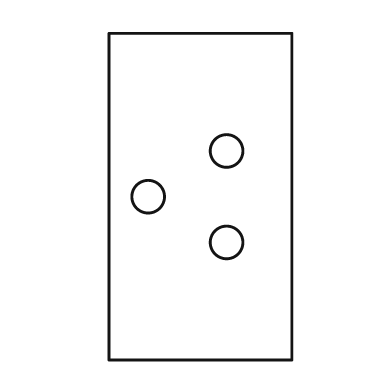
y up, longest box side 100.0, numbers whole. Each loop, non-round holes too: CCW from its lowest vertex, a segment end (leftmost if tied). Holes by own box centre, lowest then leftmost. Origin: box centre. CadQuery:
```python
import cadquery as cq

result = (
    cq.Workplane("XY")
    .moveTo(-28.0, -50.0)
    .lineTo(28.0, -50.0)
    .lineTo(28.0, 50.0)
    .lineTo(-28.0, 50.0)
    .close()
    .moveTo(8.0, -14.0)
    .circle(5.0)
    .moveTo(-16.0, 0.0)
    .circle(5.0)
    .moveTo(8.0, 14.0)
    .circle(5.0)
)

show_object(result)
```